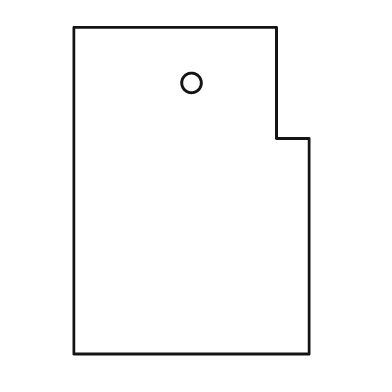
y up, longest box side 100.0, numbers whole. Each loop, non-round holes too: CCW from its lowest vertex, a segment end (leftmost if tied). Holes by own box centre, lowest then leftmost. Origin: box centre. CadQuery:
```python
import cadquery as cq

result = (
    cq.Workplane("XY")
    .moveTo(-36.0, -50.0)
    .lineTo(36.0, -50.0)
    .lineTo(36.0, 16.0)
    .lineTo(26.0, 16.0)
    .lineTo(26.0, 50.0)
    .lineTo(-36.0, 50.0)
    .close()
    .moveTo(0.0, 33.0)
    .circle(3.0)
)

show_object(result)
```